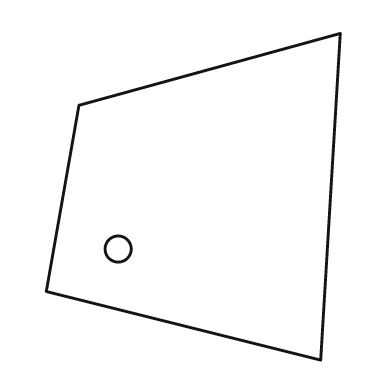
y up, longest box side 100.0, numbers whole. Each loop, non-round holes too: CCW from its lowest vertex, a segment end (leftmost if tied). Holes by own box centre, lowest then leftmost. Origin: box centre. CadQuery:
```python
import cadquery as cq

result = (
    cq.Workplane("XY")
    .moveTo(39.0, -50.0)
    .lineTo(45.0, 50.0)
    .lineTo(-35.0, 28.0)
    .lineTo(-45.0, -29.0)
    .close()
    .moveTo(-23.0, -16.0)
    .circle(4.0)
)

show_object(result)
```